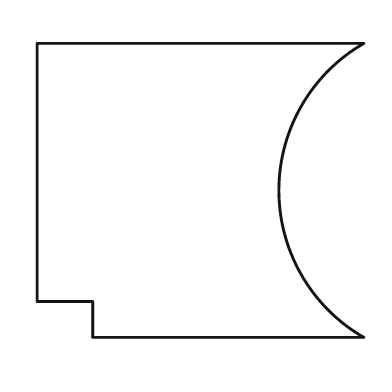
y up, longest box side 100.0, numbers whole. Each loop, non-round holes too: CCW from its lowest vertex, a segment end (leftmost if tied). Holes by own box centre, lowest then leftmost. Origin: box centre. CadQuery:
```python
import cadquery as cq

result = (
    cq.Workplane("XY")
    .moveTo(-33.0, -45.0)
    .lineTo(50.0, -45.0)
    .threePointArc((24.0, 0.0), (50.0, 45.0))
    .lineTo(-50.0, 45.0)
    .lineTo(-50.0, -34.0)
    .lineTo(-33.0, -34.0)
    .close()
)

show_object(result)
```